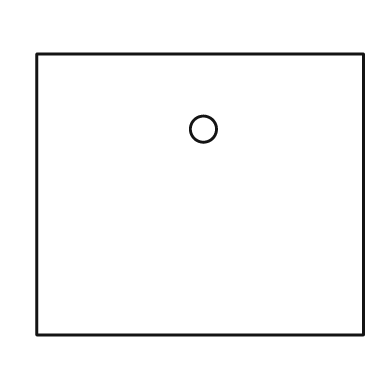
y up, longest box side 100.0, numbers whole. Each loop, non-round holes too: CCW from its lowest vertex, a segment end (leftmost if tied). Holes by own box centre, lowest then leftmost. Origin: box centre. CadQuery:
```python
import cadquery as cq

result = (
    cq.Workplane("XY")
    .moveTo(-50.0, -43.0)
    .lineTo(50.0, -43.0)
    .lineTo(50.0, 43.0)
    .lineTo(-50.0, 43.0)
    .close()
    .moveTo(1.0, 20.0)
    .circle(4.0)
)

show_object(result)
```